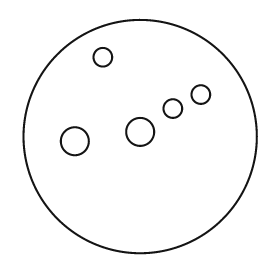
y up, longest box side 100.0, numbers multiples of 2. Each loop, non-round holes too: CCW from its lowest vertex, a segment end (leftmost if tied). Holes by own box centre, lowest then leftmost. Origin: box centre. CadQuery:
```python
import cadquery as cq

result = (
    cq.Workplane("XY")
    .moveTo(0.0, 0.0)
    .circle(50.0)
    .moveTo(-28.0, -2.0)
    .circle(6.0)
    .moveTo(0.0, 2.0)
    .circle(6.0)
    .moveTo(14.0, 12.0)
    .circle(4.0)
    .moveTo(26.0, 18.0)
    .circle(4.0)
    .moveTo(-16.0, 34.0)
    .circle(4.0)
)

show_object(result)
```